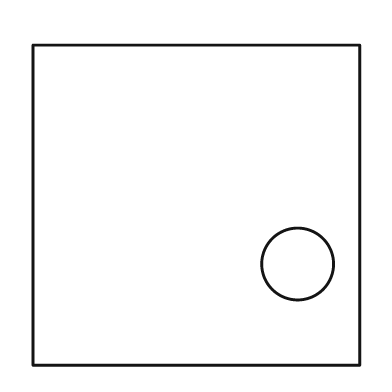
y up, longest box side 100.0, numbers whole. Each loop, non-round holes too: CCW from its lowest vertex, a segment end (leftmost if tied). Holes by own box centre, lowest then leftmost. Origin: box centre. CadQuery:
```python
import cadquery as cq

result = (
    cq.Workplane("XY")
    .moveTo(-50.0, -49.0)
    .lineTo(50.0, -49.0)
    .lineTo(50.0, 49.0)
    .lineTo(-50.0, 49.0)
    .close()
    .moveTo(31.0, -18.0)
    .circle(11.0)
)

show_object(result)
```